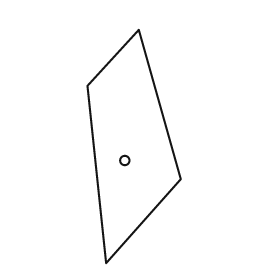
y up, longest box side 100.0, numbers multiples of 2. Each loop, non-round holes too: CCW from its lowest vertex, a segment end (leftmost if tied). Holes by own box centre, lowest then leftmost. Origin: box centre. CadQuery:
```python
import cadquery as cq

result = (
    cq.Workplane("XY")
    .moveTo(-12.0, -50.0)
    .lineTo(20.0, -14.0)
    .lineTo(2.0, 50.0)
    .lineTo(-20.0, 26.0)
    .close()
    .moveTo(-4.0, -6.0)
    .circle(2.0)
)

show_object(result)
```